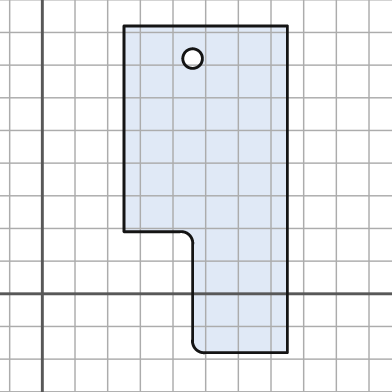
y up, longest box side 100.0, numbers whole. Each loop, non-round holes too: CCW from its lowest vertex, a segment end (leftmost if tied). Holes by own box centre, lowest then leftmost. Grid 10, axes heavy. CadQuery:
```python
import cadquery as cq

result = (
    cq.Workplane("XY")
    .moveTo(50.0, -18.0)
    .lineTo(75.0, -18.0)
    .lineTo(75.0, 82.0)
    .lineTo(25.0, 82.0)
    .lineTo(25.0, 19.0)
    .lineTo(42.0, 19.0)
    .threePointArc((45.0, 18.0), (46.0, 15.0))
    .lineTo(46.0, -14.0)
    .threePointArc((47.0, -17.0), (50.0, -18.0))
    .close()
    .moveTo(46.0, 72.0)
    .circle(3.0)
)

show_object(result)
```